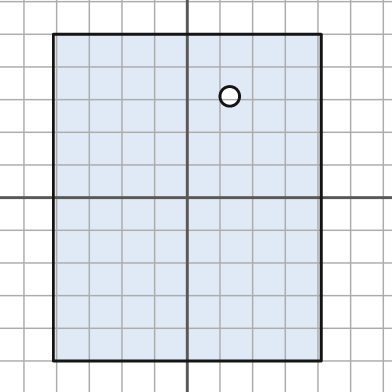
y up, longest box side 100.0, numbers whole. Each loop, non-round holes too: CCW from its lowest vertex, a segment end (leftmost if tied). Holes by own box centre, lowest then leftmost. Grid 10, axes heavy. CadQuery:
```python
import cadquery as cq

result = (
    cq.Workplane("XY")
    .moveTo(-41.0, -50.0)
    .lineTo(41.0, -50.0)
    .lineTo(41.0, 50.0)
    .lineTo(-41.0, 50.0)
    .close()
    .moveTo(13.0, 31.0)
    .circle(3.0)
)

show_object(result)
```